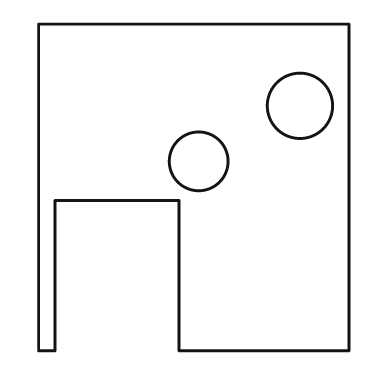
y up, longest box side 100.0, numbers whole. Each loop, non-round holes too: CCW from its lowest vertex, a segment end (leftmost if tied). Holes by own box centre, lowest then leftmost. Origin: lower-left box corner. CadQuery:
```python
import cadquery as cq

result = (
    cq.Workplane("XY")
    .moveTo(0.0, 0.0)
    .lineTo(5.0, 0.0)
    .lineTo(5.0, 46.0)
    .lineTo(43.0, 46.0)
    .lineTo(43.0, 0.0)
    .lineTo(95.0, 0.0)
    .lineTo(95.0, 100.0)
    .lineTo(0.0, 100.0)
    .close()
    .moveTo(49.0, 58.0)
    .circle(9.0)
    .moveTo(80.0, 75.0)
    .circle(10.0)
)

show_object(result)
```